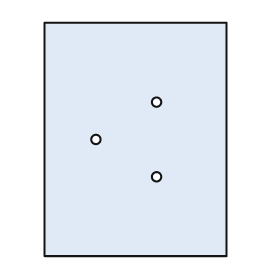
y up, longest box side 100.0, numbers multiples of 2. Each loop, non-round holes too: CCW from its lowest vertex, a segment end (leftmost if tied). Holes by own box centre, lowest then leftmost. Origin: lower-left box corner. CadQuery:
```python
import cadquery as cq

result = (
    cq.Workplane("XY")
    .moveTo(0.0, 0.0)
    .lineTo(78.0, 0.0)
    .lineTo(78.0, 100.0)
    .lineTo(0.0, 100.0)
    .close()
    .moveTo(48.0, 34.0)
    .circle(2.0)
    .moveTo(22.0, 50.0)
    .circle(2.0)
    .moveTo(48.0, 66.0)
    .circle(2.0)
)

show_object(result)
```